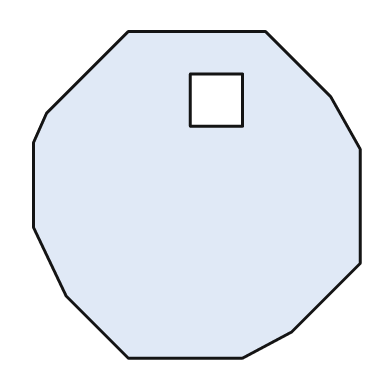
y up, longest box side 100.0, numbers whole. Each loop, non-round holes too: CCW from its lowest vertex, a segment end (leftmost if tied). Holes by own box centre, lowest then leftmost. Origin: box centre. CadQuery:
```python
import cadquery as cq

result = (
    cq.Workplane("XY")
    .moveTo(-21.0, -50.0)
    .lineTo(14.0, -50.0)
    .lineTo(29.0, -42.0)
    .lineTo(50.0, -21.0)
    .lineTo(50.0, 14.0)
    .lineTo(41.0, 30.0)
    .lineTo(21.0, 50.0)
    .lineTo(-21.0, 50.0)
    .lineTo(-46.0, 25.0)
    .lineTo(-50.0, 16.0)
    .lineTo(-50.0, -10.0)
    .lineTo(-40.0, -31.0)
    .close()
    .moveTo(-2.0, 21.0)
    .lineTo(14.0, 21.0)
    .lineTo(14.0, 37.0)
    .lineTo(-2.0, 37.0)
    .close()
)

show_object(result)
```